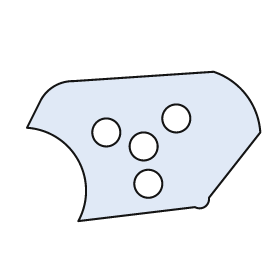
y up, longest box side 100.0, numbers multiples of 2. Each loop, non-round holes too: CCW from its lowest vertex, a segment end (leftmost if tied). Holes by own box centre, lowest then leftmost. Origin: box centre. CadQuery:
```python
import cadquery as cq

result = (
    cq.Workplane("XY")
    .moveTo(-28.0, -32.0)
    .lineTo(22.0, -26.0)
    .threePointArc((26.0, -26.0), (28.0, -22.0))
    .lineTo(50.0, 6.0)
    .threePointArc((44.0, 22.0), (30.0, 32.0))
    .lineTo(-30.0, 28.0)
    .threePointArc((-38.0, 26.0), (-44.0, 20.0))
    .lineTo(-50.0, 8.0)
    .threePointArc((-28.0, -6.0), (-28.0, -32.0))
    .close()
    .moveTo(2.0, -16.0)
    .circle(6.0)
    .moveTo(0.0, 0.0)
    .circle(6.0)
    .moveTo(-16.0, 6.0)
    .circle(6.0)
    .moveTo(14.0, 12.0)
    .circle(6.0)
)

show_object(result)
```